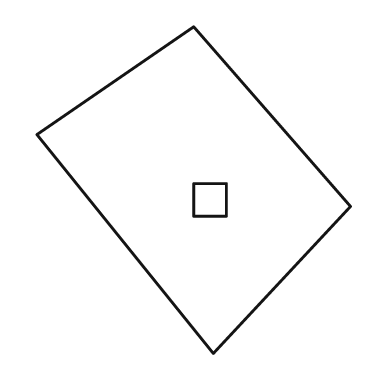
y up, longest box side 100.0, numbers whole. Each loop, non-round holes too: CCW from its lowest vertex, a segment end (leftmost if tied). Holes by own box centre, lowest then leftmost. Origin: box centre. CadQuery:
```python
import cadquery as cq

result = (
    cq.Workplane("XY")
    .moveTo(6.0, -50.0)
    .lineTo(48.0, -5.0)
    .lineTo(0.0, 50.0)
    .lineTo(-48.0, 17.0)
    .close()
    .moveTo(0.0, -8.0)
    .lineTo(10.0, -8.0)
    .lineTo(10.0, 2.0)
    .lineTo(0.0, 2.0)
    .close()
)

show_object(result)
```